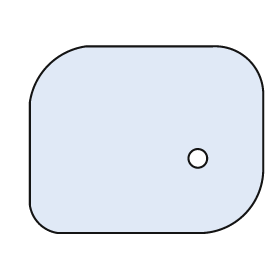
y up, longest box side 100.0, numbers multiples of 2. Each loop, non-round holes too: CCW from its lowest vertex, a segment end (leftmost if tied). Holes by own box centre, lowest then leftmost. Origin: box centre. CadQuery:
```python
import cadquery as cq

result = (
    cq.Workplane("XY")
    .moveTo(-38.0, -40.0)
    .lineTo(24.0, -40.0)
    .threePointArc((42.0, -32.0), (50.0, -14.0))
    .lineTo(50.0, 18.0)
    .threePointArc((44.0, 34.0), (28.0, 40.0))
    .lineTo(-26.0, 40.0)
    .threePointArc((-42.0, 32.0), (-50.0, 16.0))
    .lineTo(-50.0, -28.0)
    .threePointArc((-46.0, -36.0), (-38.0, -40.0))
    .close()
    .moveTo(22.0, -8.0)
    .circle(4.0)
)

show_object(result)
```